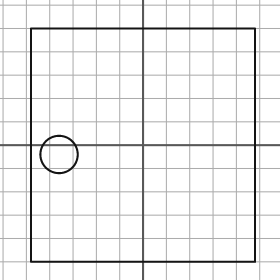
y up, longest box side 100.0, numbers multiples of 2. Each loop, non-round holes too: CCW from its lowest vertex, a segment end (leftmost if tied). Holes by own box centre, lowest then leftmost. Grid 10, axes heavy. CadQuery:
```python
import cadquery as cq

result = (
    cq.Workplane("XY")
    .moveTo(-48.0, -50.0)
    .lineTo(48.0, -50.0)
    .lineTo(48.0, 50.0)
    .lineTo(-48.0, 50.0)
    .close()
    .moveTo(-36.0, -4.0)
    .circle(8.0)
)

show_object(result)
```